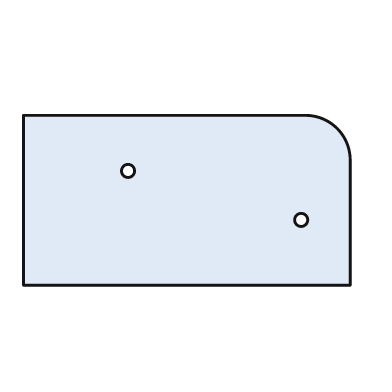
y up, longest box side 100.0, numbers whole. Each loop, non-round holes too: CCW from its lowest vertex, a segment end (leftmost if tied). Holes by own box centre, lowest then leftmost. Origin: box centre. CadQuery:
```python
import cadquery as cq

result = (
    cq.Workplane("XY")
    .moveTo(-50.0, -26.0)
    .lineTo(50.0, -26.0)
    .lineTo(50.0, 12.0)
    .threePointArc((46.0, 22.0), (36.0, 26.0))
    .lineTo(-50.0, 26.0)
    .close()
    .moveTo(35.0, -6.0)
    .circle(2.0)
    .moveTo(-18.0, 9.0)
    .circle(2.0)
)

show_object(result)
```